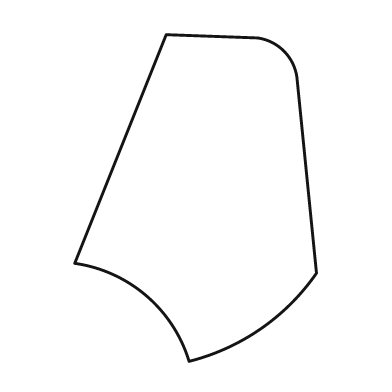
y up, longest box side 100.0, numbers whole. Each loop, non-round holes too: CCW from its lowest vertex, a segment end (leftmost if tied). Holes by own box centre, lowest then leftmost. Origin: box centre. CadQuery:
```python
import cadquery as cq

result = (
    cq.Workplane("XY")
    .moveTo(-2.0, -50.0)
    .threePointArc((20.0, -40.0), (37.0, -23.0))
    .lineTo(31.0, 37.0)
    .threePointArc((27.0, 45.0), (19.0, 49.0))
    .lineTo(-9.0, 50.0)
    .lineTo(-37.0, -20.0)
    .threePointArc((-15.0, -30.0), (-2.0, -50.0))
    .close()
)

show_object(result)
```